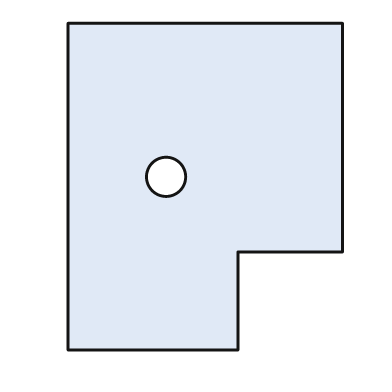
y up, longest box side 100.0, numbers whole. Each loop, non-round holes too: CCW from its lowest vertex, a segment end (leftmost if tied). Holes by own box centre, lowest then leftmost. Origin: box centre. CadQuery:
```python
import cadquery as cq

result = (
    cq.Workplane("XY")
    .moveTo(-42.0, -50.0)
    .lineTo(10.0, -50.0)
    .lineTo(10.0, -20.0)
    .lineTo(42.0, -20.0)
    .lineTo(42.0, 50.0)
    .lineTo(-42.0, 50.0)
    .close()
    .moveTo(-12.0, 3.0)
    .circle(6.0)
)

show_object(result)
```